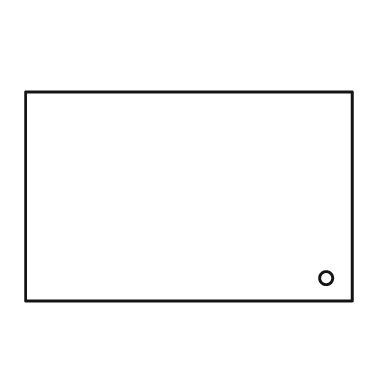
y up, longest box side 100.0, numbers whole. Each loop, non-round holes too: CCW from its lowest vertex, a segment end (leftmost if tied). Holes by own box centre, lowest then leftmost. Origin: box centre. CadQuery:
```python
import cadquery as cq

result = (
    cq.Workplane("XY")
    .moveTo(-50.0, -32.0)
    .lineTo(50.0, -32.0)
    .lineTo(50.0, 32.0)
    .lineTo(-50.0, 32.0)
    .close()
    .moveTo(42.0, -25.0)
    .circle(2.0)
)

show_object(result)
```